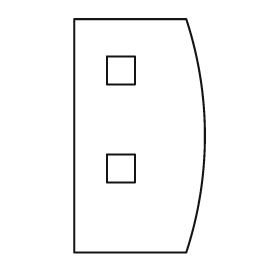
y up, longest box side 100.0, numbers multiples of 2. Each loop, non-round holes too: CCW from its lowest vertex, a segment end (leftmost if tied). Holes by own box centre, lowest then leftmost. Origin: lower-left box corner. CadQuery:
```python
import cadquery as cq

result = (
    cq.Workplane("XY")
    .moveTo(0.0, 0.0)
    .lineTo(48.0, 0.0)
    .threePointArc((56.0, 50.0), (48.0, 100.0))
    .lineTo(0.0, 100.0)
    .close()
    .moveTo(14.0, 30.0)
    .lineTo(26.0, 30.0)
    .lineTo(26.0, 42.0)
    .lineTo(14.0, 42.0)
    .close()
    .moveTo(14.0, 72.0)
    .lineTo(26.0, 72.0)
    .lineTo(26.0, 84.0)
    .lineTo(14.0, 84.0)
    .close()
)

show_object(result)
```